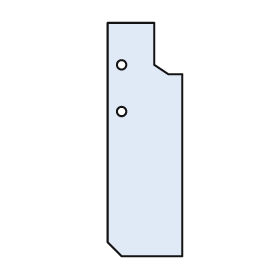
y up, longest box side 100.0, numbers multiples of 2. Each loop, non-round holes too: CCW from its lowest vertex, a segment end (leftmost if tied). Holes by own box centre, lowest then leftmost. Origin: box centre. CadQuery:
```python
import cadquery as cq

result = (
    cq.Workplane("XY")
    .moveTo(-10.0, -50.0)
    .lineTo(16.0, -50.0)
    .lineTo(16.0, 28.0)
    .lineTo(10.0, 28.0)
    .lineTo(4.0, 32.0)
    .lineTo(4.0, 50.0)
    .lineTo(-16.0, 50.0)
    .lineTo(-16.0, -44.0)
    .close()
    .moveTo(-10.0, 12.0)
    .circle(2.0)
    .moveTo(-10.0, 32.0)
    .circle(2.0)
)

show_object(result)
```